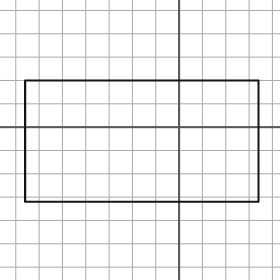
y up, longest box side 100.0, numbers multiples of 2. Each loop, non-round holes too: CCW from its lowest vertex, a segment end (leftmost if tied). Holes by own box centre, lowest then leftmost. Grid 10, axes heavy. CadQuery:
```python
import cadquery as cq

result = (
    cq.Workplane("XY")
    .moveTo(-66.0, -32.0)
    .lineTo(34.0, -32.0)
    .lineTo(34.0, 20.0)
    .lineTo(-66.0, 20.0)
    .close()
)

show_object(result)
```